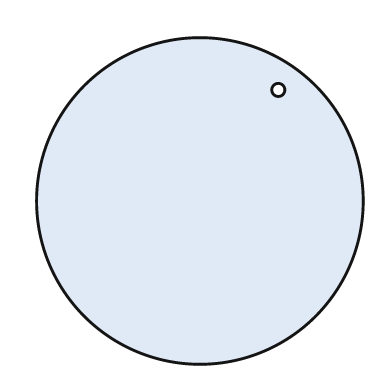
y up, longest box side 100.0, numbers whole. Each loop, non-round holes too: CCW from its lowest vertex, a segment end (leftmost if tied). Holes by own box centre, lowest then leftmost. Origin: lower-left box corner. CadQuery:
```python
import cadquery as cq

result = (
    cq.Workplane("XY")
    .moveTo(50.0, 50.0)
    .circle(50.0)
    .moveTo(74.0, 84.0)
    .circle(2.0)
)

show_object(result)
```